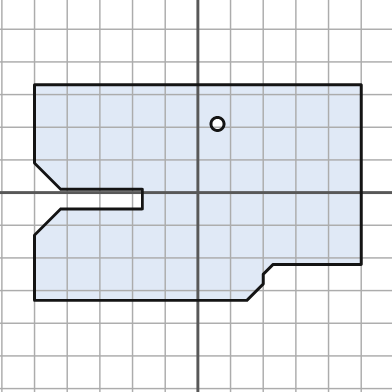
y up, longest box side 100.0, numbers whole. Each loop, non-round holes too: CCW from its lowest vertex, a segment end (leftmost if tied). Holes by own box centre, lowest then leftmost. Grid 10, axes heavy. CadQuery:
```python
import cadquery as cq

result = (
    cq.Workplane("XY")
    .moveTo(-50.0, -33.0)
    .lineTo(15.0, -33.0)
    .lineTo(20.0, -28.0)
    .lineTo(20.0, -25.0)
    .lineTo(23.0, -22.0)
    .lineTo(50.0, -22.0)
    .lineTo(50.0, 33.0)
    .lineTo(-50.0, 33.0)
    .lineTo(-50.0, 9.0)
    .lineTo(-42.0, 1.0)
    .lineTo(-17.0, 1.0)
    .lineTo(-17.0, -5.0)
    .lineTo(-42.0, -5.0)
    .lineTo(-50.0, -13.0)
    .close()
    .moveTo(6.0, 21.0)
    .circle(2.0)
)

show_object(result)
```